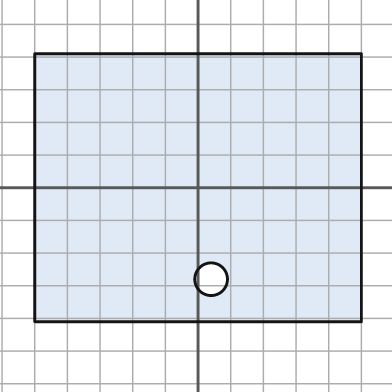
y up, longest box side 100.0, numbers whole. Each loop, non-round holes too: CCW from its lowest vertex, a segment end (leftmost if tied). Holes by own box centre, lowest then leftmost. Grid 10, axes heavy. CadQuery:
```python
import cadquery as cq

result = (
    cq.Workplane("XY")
    .moveTo(-50.0, -41.0)
    .lineTo(50.0, -41.0)
    .lineTo(50.0, 41.0)
    .lineTo(-50.0, 41.0)
    .close()
    .moveTo(4.0, -28.0)
    .circle(5.0)
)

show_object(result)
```